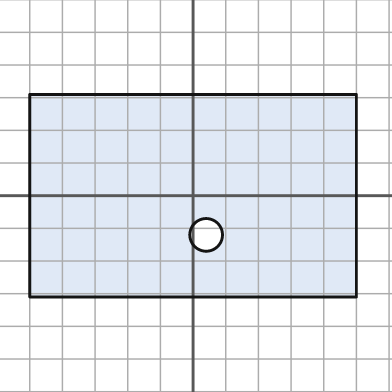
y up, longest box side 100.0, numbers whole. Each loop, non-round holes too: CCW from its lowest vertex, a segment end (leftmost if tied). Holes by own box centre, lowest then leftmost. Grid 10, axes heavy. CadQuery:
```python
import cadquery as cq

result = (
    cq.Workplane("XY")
    .moveTo(-50.0, -31.0)
    .lineTo(50.0, -31.0)
    .lineTo(50.0, 31.0)
    .lineTo(-50.0, 31.0)
    .close()
    .moveTo(4.0, -12.0)
    .circle(5.0)
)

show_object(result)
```